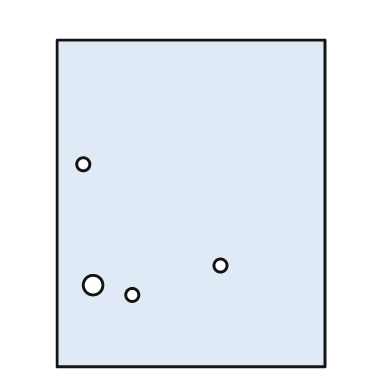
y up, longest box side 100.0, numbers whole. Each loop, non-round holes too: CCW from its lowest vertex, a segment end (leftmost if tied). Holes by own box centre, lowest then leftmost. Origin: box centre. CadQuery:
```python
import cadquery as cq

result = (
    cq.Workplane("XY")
    .moveTo(-41.0, -50.0)
    .lineTo(41.0, -50.0)
    .lineTo(41.0, 50.0)
    .lineTo(-41.0, 50.0)
    .close()
    .moveTo(-18.0, -28.0)
    .circle(2.0)
    .moveTo(-30.0, -25.0)
    .circle(3.0)
    .moveTo(9.0, -19.0)
    .circle(2.0)
    .moveTo(-33.0, 12.0)
    .circle(2.0)
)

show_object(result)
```